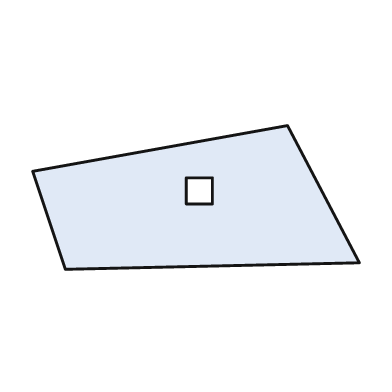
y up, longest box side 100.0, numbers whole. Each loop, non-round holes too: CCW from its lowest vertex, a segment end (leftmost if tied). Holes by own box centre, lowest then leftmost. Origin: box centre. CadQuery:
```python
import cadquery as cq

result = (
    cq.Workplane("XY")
    .moveTo(-40.0, -22.0)
    .lineTo(50.0, -20.0)
    .lineTo(28.0, 22.0)
    .lineTo(-50.0, 8.0)
    .close()
    .moveTo(-3.0, -2.0)
    .lineTo(5.0, -2.0)
    .lineTo(5.0, 6.0)
    .lineTo(-3.0, 6.0)
    .close()
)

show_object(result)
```